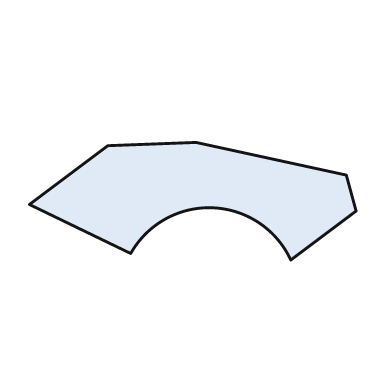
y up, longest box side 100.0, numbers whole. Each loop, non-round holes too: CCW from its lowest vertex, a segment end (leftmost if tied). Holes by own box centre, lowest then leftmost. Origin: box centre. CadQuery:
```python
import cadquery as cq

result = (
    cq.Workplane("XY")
    .moveTo(30.0, -18.0)
    .lineTo(50.0, -3.0)
    .lineTo(47.0, 8.0)
    .lineTo(1.0, 18.0)
    .lineTo(-26.0, 17.0)
    .lineTo(-50.0, -1.0)
    .lineTo(-19.0, -16.0)
    .threePointArc((6.0, -2.0), (30.0, -18.0))
    .close()
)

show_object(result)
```